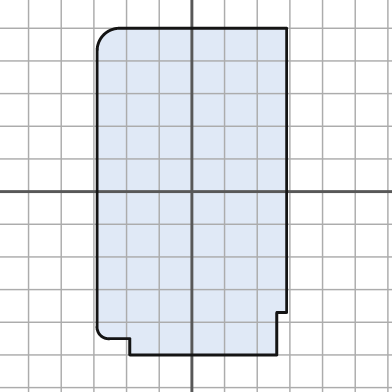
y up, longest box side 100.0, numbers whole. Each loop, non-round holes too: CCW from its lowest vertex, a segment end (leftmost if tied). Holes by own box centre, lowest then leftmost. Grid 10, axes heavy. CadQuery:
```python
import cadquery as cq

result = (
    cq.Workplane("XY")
    .moveTo(-19.0, -50.0)
    .lineTo(26.0, -50.0)
    .lineTo(26.0, -37.0)
    .lineTo(29.0, -37.0)
    .lineTo(29.0, 50.0)
    .lineTo(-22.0, 50.0)
    .threePointArc((-27.0, 48.0), (-29.0, 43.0))
    .lineTo(-29.0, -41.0)
    .threePointArc((-28.0, -44.0), (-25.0, -45.0))
    .lineTo(-19.0, -45.0)
    .close()
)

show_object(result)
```